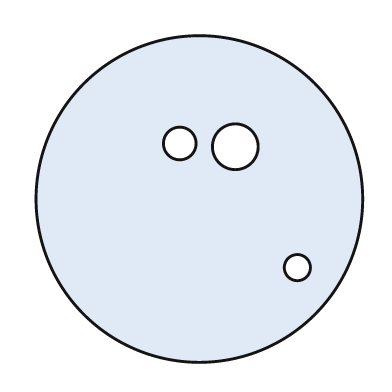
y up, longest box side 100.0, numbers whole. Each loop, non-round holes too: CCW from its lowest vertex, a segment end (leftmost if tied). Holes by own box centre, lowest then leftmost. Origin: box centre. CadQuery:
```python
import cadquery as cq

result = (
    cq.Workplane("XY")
    .moveTo(0.0, 0.0)
    .circle(50.0)
    .moveTo(30.0, -21.0)
    .circle(4.0)
    .moveTo(11.0, 16.0)
    .circle(7.0)
    .moveTo(-6.0, 17.0)
    .circle(5.0)
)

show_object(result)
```